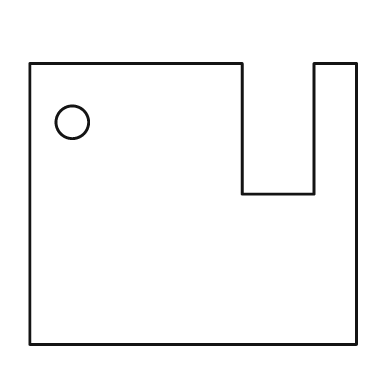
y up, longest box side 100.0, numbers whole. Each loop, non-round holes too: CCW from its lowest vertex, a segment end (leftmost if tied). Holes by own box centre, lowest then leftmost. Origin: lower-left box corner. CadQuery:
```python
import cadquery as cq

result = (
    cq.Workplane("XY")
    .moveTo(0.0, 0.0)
    .lineTo(100.0, 0.0)
    .lineTo(100.0, 86.0)
    .lineTo(87.0, 86.0)
    .lineTo(87.0, 46.0)
    .lineTo(65.0, 46.0)
    .lineTo(65.0, 86.0)
    .lineTo(0.0, 86.0)
    .close()
    .moveTo(13.0, 68.0)
    .circle(5.0)
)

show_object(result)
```